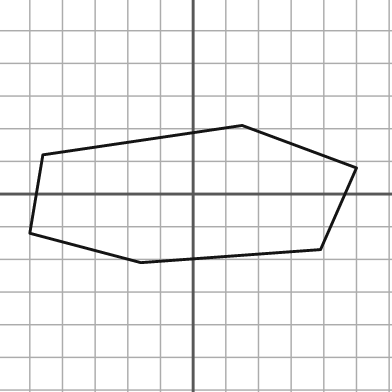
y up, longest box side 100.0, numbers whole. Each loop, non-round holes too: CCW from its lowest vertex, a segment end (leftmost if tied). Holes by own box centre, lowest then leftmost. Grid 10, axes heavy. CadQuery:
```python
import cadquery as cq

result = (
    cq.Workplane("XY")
    .moveTo(-16.0, -21.0)
    .lineTo(39.0, -17.0)
    .lineTo(50.0, 8.0)
    .lineTo(15.0, 21.0)
    .lineTo(-46.0, 12.0)
    .lineTo(-50.0, -12.0)
    .close()
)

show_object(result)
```